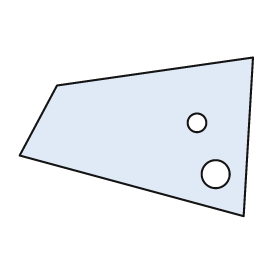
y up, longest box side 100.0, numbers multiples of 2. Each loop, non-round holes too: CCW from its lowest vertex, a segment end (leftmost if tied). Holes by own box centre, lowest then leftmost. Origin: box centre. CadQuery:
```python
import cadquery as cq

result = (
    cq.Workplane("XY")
    .moveTo(46.0, -34.0)
    .lineTo(50.0, 34.0)
    .lineTo(-34.0, 22.0)
    .lineTo(-50.0, -8.0)
    .close()
    .moveTo(34.0, -16.0)
    .circle(6.0)
    .moveTo(26.0, 6.0)
    .circle(4.0)
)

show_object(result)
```